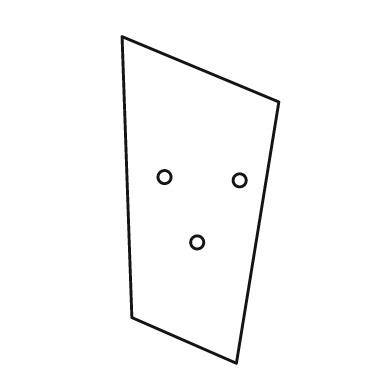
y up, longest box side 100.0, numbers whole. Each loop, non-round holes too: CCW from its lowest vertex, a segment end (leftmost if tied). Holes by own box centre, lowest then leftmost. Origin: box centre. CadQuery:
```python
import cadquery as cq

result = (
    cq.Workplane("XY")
    .moveTo(11.0, -50.0)
    .lineTo(24.0, 30.0)
    .lineTo(-24.0, 50.0)
    .lineTo(-21.0, -36.0)
    .close()
    .moveTo(-1.0, -13.0)
    .circle(2.0)
    .moveTo(12.0, 6.0)
    .circle(2.0)
    .moveTo(-11.0, 7.0)
    .circle(2.0)
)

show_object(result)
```